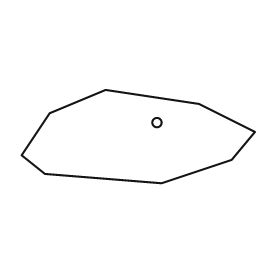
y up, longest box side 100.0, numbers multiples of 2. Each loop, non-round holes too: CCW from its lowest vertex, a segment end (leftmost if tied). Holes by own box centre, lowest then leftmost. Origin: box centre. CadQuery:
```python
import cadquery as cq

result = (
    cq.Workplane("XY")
    .moveTo(10.0, -20.0)
    .lineTo(40.0, -10.0)
    .lineTo(50.0, 2.0)
    .lineTo(26.0, 14.0)
    .lineTo(-14.0, 20.0)
    .lineTo(-38.0, 10.0)
    .lineTo(-50.0, -8.0)
    .lineTo(-40.0, -16.0)
    .close()
    .moveTo(8.0, 6.0)
    .circle(2.0)
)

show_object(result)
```